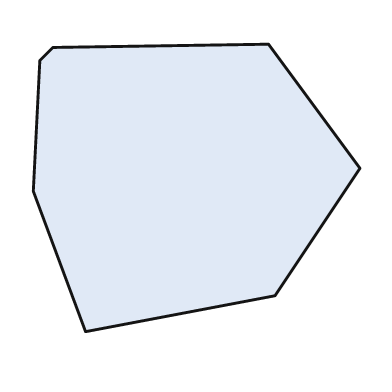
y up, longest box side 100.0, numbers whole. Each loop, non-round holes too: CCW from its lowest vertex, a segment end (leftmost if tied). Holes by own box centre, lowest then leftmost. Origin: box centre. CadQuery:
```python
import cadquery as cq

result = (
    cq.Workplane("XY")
    .moveTo(-34.0, -44.0)
    .lineTo(24.0, -33.0)
    .lineTo(50.0, 6.0)
    .lineTo(22.0, 44.0)
    .lineTo(-44.0, 43.0)
    .lineTo(-48.0, 39.0)
    .lineTo(-50.0, -1.0)
    .close()
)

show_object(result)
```